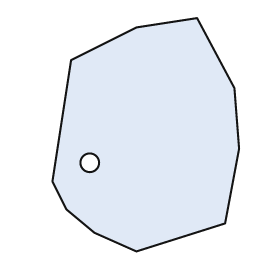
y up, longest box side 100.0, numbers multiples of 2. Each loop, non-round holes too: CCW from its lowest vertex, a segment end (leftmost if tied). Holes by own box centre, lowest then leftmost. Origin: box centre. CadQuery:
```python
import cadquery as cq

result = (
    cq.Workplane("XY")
    .moveTo(-4.0, -50.0)
    .lineTo(34.0, -38.0)
    .lineTo(40.0, -6.0)
    .lineTo(38.0, 20.0)
    .lineTo(22.0, 50.0)
    .lineTo(-4.0, 46.0)
    .lineTo(-32.0, 32.0)
    .lineTo(-40.0, -20.0)
    .lineTo(-34.0, -32.0)
    .lineTo(-22.0, -42.0)
    .close()
    .moveTo(-24.0, -12.0)
    .circle(4.0)
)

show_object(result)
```